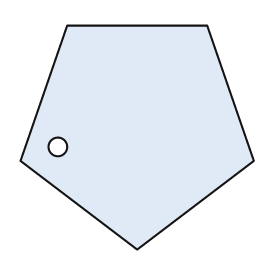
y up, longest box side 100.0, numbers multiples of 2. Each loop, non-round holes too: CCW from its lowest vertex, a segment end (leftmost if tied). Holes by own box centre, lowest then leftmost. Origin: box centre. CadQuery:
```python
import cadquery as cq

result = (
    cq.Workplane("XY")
    .moveTo(0.0, -48.0)
    .lineTo(50.0, -10.0)
    .lineTo(30.0, 48.0)
    .lineTo(-30.0, 48.0)
    .lineTo(-50.0, -10.0)
    .close()
    .moveTo(-34.0, -4.0)
    .circle(4.0)
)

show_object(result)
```